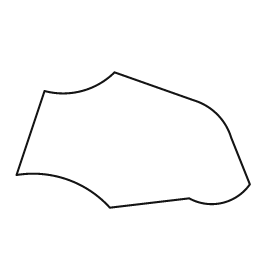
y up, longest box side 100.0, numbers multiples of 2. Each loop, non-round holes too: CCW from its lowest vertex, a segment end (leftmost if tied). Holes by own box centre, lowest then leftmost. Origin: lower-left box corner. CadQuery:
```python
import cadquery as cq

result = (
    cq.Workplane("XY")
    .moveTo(40.0, 0.0)
    .lineTo(74.0, 4.0)
    .threePointArc((88.0, 2.0), (100.0, 10.0))
    .lineTo(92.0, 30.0)
    .threePointArc((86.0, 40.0), (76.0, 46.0))
    .lineTo(42.0, 58.0)
    .threePointArc((28.0, 50.0), (12.0, 50.0))
    .lineTo(0.0, 14.0)
    .threePointArc((22.0, 12.0), (40.0, 0.0))
    .close()
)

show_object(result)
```